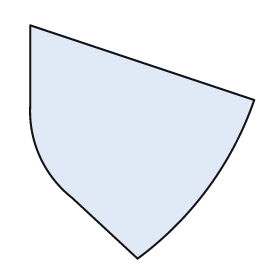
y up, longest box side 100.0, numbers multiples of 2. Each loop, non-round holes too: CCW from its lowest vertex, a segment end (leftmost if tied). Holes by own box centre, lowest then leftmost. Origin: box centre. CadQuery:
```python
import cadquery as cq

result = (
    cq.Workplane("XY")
    .moveTo(-2.0, -50.0)
    .threePointArc((28.0, -20.0), (48.0, 18.0))
    .lineTo(-48.0, 50.0)
    .lineTo(-48.0, 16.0)
    .threePointArc((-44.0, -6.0), (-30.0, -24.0))
    .close()
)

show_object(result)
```